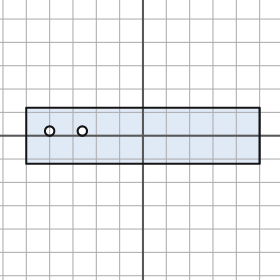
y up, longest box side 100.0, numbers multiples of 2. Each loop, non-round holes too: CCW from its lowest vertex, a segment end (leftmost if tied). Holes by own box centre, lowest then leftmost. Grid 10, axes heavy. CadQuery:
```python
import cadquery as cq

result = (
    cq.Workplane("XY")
    .moveTo(-50.0, -12.0)
    .lineTo(50.0, -12.0)
    .lineTo(50.0, 12.0)
    .lineTo(-50.0, 12.0)
    .close()
    .moveTo(-40.0, 2.0)
    .circle(2.0)
    .moveTo(-26.0, 2.0)
    .circle(2.0)
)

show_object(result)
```